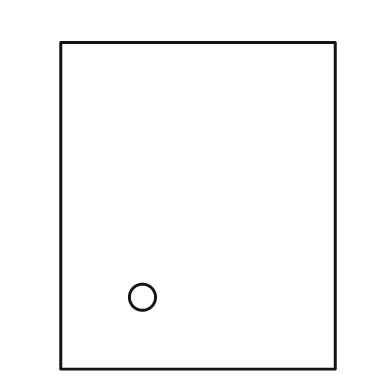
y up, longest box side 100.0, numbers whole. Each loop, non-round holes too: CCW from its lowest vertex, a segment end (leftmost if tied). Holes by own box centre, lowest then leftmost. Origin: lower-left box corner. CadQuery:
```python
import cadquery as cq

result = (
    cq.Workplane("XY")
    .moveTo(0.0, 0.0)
    .lineTo(84.0, 0.0)
    .lineTo(84.0, 100.0)
    .lineTo(0.0, 100.0)
    .close()
    .moveTo(25.0, 22.0)
    .circle(4.0)
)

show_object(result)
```